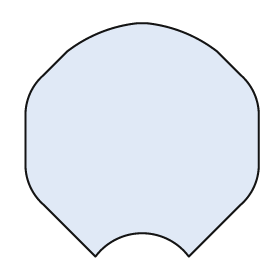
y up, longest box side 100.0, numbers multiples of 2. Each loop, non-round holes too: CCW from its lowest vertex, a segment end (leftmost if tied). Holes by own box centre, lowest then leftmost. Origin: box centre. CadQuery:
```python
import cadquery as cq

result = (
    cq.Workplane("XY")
    .moveTo(-20.0, -50.0)
    .threePointArc((0.0, -40.0), (20.0, -50.0))
    .lineTo(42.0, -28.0)
    .threePointArc((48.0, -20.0), (50.0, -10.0))
    .lineTo(50.0, 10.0)
    .threePointArc((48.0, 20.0), (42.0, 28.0))
    .lineTo(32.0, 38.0)
    .threePointArc((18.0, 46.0), (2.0, 50.0))
    .lineTo(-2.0, 50.0)
    .threePointArc((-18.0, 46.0), (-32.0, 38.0))
    .lineTo(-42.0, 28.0)
    .threePointArc((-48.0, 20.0), (-50.0, 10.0))
    .lineTo(-50.0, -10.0)
    .threePointArc((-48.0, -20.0), (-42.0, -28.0))
    .close()
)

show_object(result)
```